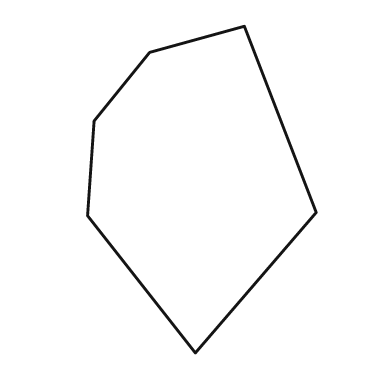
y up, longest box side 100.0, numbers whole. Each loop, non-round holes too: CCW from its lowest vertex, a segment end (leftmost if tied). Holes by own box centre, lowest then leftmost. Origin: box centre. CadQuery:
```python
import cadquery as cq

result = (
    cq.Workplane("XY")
    .moveTo(-2.0, -50.0)
    .lineTo(35.0, -7.0)
    .lineTo(13.0, 50.0)
    .lineTo(-16.0, 42.0)
    .lineTo(-33.0, 21.0)
    .lineTo(-35.0, -8.0)
    .close()
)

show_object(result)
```